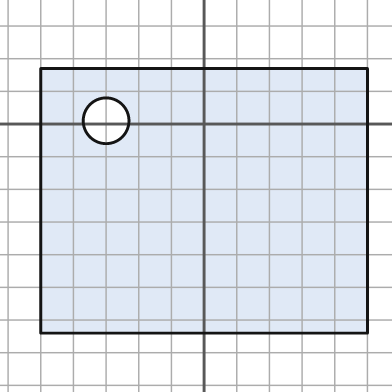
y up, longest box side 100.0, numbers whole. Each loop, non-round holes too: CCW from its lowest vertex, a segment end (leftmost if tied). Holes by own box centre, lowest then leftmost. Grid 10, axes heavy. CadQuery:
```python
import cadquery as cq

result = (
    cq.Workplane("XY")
    .moveTo(-50.0, -64.0)
    .lineTo(50.0, -64.0)
    .lineTo(50.0, 17.0)
    .lineTo(-50.0, 17.0)
    .close()
    .moveTo(-30.0, 1.0)
    .circle(7.0)
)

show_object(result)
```